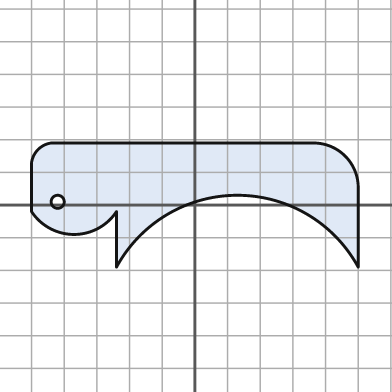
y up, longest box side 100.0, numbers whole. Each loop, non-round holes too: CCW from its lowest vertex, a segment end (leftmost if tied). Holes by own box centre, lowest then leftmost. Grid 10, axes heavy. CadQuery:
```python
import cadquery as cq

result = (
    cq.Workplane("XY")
    .moveTo(-24.0, -19.0)
    .threePointArc((13.0, 3.0), (50.0, -19.0))
    .lineTo(50.0, 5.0)
    .threePointArc((46.0, 15.0), (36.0, 19.0))
    .lineTo(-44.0, 19.0)
    .threePointArc((-48.0, 17.0), (-50.0, 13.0))
    .lineTo(-50.0, -2.0)
    .threePointArc((-37.0, -9.0), (-24.0, -2.0))
    .close()
    .moveTo(-42.0, 1.0)
    .circle(2.0)
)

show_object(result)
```